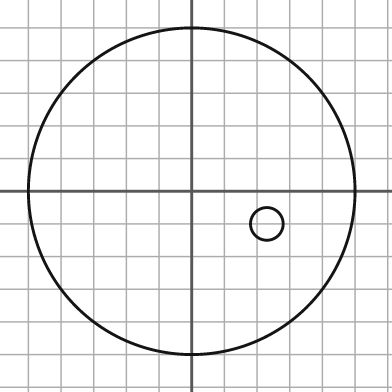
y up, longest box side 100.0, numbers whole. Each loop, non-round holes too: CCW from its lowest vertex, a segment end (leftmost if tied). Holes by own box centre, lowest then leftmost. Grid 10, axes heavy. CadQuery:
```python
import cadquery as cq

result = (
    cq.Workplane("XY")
    .moveTo(0.0, 0.0)
    .circle(50.0)
    .moveTo(23.0, -10.0)
    .circle(5.0)
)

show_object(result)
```